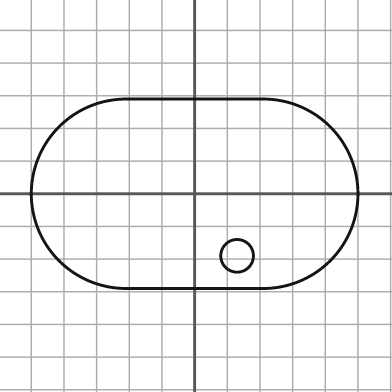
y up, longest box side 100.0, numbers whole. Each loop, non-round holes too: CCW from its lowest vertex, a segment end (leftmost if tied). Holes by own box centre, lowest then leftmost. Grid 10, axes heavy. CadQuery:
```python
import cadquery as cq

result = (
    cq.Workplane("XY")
    .moveTo(-21.0, -29.0)
    .lineTo(21.0, -29.0)
    .threePointArc((50.0, 0.0), (21.0, 29.0))
    .lineTo(-21.0, 29.0)
    .threePointArc((-50.0, 0.0), (-21.0, -29.0))
    .close()
    .moveTo(13.0, -19.0)
    .circle(5.0)
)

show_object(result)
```